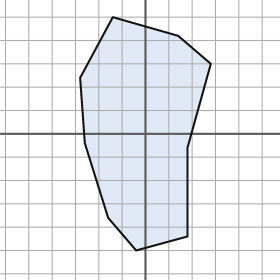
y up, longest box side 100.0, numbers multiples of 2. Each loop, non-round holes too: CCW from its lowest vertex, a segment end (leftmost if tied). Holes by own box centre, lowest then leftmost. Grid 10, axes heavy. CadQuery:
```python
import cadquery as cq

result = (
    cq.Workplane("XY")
    .moveTo(-4.0, -50.0)
    .lineTo(18.0, -44.0)
    .lineTo(18.0, -6.0)
    .lineTo(28.0, 30.0)
    .lineTo(14.0, 42.0)
    .lineTo(-14.0, 50.0)
    .lineTo(-28.0, 24.0)
    .lineTo(-26.0, -4.0)
    .lineTo(-16.0, -36.0)
    .close()
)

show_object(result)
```